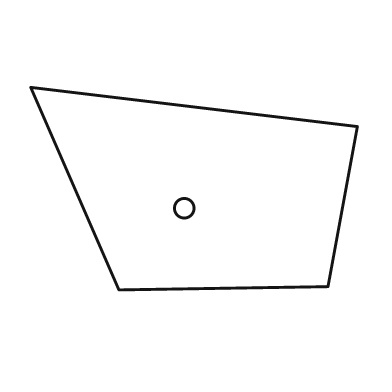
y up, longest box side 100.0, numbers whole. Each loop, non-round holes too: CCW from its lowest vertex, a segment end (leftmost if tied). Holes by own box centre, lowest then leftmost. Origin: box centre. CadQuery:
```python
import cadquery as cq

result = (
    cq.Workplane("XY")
    .moveTo(-23.0, -31.0)
    .lineTo(41.0, -30.0)
    .lineTo(50.0, 19.0)
    .lineTo(-50.0, 31.0)
    .close()
    .moveTo(-3.0, -6.0)
    .circle(3.0)
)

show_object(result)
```